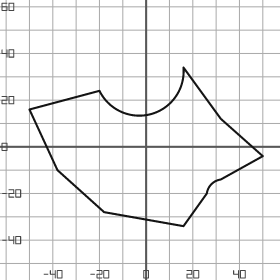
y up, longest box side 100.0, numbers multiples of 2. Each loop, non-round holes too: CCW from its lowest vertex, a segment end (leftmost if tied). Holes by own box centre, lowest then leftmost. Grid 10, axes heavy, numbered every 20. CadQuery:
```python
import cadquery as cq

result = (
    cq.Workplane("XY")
    .moveTo(16.0, -34.0)
    .lineTo(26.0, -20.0)
    .threePointArc((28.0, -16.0), (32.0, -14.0))
    .lineTo(50.0, -4.0)
    .lineTo(32.0, 12.0)
    .lineTo(16.0, 34.0)
    .threePointArc((2.0, 14.0), (-20.0, 24.0))
    .lineTo(-50.0, 16.0)
    .lineTo(-38.0, -10.0)
    .lineTo(-18.0, -28.0)
    .close()
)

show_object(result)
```